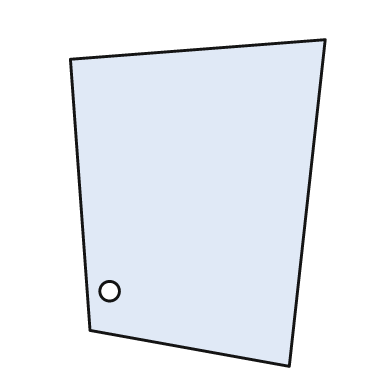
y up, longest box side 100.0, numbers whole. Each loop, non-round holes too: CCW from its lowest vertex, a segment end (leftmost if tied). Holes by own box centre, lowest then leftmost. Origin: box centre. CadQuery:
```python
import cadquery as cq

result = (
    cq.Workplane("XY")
    .moveTo(28.0, -50.0)
    .lineTo(39.0, 50.0)
    .lineTo(-39.0, 44.0)
    .lineTo(-33.0, -39.0)
    .close()
    .moveTo(-27.0, -27.0)
    .circle(3.0)
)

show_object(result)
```